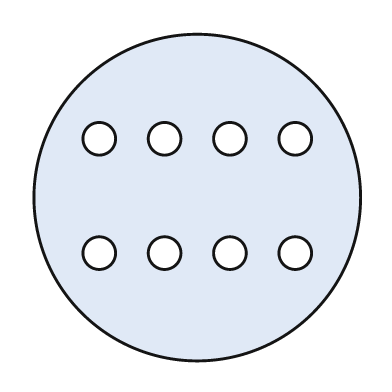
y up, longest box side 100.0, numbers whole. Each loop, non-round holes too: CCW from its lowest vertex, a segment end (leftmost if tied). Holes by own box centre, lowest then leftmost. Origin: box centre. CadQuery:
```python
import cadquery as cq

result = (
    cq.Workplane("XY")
    .moveTo(0.0, 0.0)
    .circle(50.0)
    .moveTo(-30.0, -17.0)
    .circle(5.0)
    .moveTo(-10.0, -17.0)
    .circle(5.0)
    .moveTo(10.0, -17.0)
    .circle(5.0)
    .moveTo(30.0, -17.0)
    .circle(5.0)
    .moveTo(-30.0, 18.0)
    .circle(5.0)
    .moveTo(-10.0, 18.0)
    .circle(5.0)
    .moveTo(10.0, 18.0)
    .circle(5.0)
    .moveTo(30.0, 18.0)
    .circle(5.0)
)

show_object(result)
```